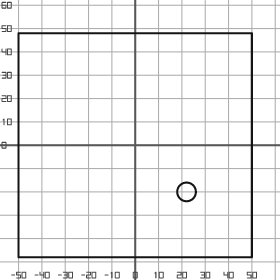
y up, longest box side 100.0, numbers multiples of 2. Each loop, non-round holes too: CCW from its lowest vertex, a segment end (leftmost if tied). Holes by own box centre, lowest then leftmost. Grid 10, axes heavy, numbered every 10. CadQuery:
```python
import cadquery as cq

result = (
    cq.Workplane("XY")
    .moveTo(-50.0, -48.0)
    .lineTo(50.0, -48.0)
    .lineTo(50.0, 48.0)
    .lineTo(-50.0, 48.0)
    .close()
    .moveTo(22.0, -20.0)
    .circle(4.0)
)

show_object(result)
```